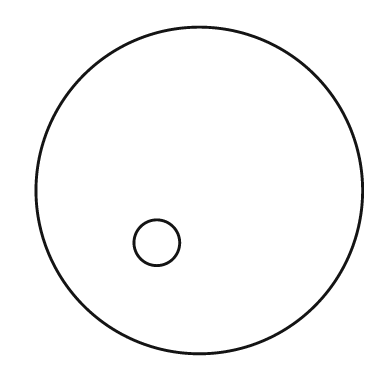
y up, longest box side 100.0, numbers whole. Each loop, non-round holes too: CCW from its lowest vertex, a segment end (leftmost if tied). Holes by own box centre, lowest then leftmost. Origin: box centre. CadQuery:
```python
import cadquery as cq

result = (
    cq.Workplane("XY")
    .moveTo(0.0, 0.0)
    .circle(50.0)
    .moveTo(-13.0, -16.0)
    .circle(7.0)
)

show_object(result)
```